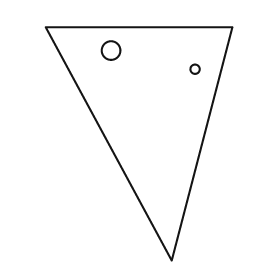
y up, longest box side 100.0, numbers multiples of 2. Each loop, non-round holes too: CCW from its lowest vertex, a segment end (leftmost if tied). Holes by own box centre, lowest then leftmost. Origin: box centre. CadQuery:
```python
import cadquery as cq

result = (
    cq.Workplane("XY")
    .moveTo(14.0, -50.0)
    .lineTo(40.0, 50.0)
    .lineTo(-40.0, 50.0)
    .close()
    .moveTo(24.0, 32.0)
    .circle(2.0)
    .moveTo(-12.0, 40.0)
    .circle(4.0)
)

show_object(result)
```